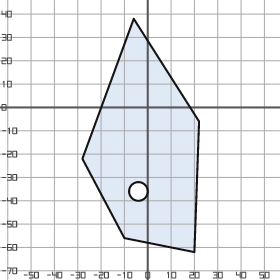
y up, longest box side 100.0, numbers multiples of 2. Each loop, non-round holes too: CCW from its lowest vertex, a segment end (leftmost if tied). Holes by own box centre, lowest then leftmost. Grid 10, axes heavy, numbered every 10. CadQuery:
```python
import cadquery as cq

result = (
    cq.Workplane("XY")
    .moveTo(20.0, -62.0)
    .lineTo(22.0, -6.0)
    .lineTo(-6.0, 38.0)
    .lineTo(-28.0, -22.0)
    .lineTo(-10.0, -56.0)
    .close()
    .moveTo(-4.0, -36.0)
    .circle(4.0)
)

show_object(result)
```